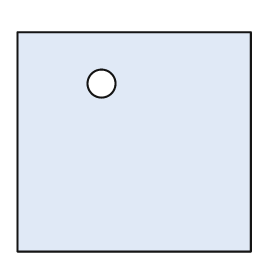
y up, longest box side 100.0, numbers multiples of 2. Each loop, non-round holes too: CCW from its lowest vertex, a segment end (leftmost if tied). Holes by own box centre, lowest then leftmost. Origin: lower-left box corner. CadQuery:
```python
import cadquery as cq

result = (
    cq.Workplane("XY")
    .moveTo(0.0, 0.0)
    .lineTo(100.0, 0.0)
    .lineTo(100.0, 94.0)
    .lineTo(0.0, 94.0)
    .close()
    .moveTo(36.0, 72.0)
    .circle(6.0)
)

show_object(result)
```